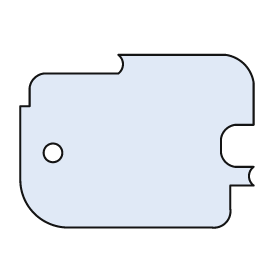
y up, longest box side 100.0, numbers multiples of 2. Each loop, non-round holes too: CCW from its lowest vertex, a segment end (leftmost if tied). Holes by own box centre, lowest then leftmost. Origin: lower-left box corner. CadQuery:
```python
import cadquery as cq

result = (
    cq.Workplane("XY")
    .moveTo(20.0, 0.0)
    .lineTo(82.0, 0.0)
    .threePointArc((88.0, 2.0), (90.0, 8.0))
    .lineTo(90.0, 18.0)
    .lineTo(100.0, 18.0)
    .threePointArc((98.0, 22.0), (100.0, 26.0))
    .lineTo(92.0, 26.0)
    .threePointArc((88.0, 28.0), (86.0, 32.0))
    .lineTo(86.0, 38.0)
    .threePointArc((88.0, 42.0), (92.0, 44.0))
    .lineTo(100.0, 44.0)
    .lineTo(100.0, 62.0)
    .threePointArc((96.0, 70.0), (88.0, 74.0))
    .lineTo(42.0, 74.0)
    .threePointArc((44.0, 70.0), (42.0, 66.0))
    .lineTo(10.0, 66.0)
    .threePointArc((6.0, 64.0), (4.0, 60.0))
    .lineTo(4.0, 52.0)
    .lineTo(0.0, 52.0)
    .lineTo(0.0, 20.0)
    .threePointArc((6.0, 6.0), (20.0, 0.0))
    .close()
    .moveTo(14.0, 32.0)
    .circle(4.0)
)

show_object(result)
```